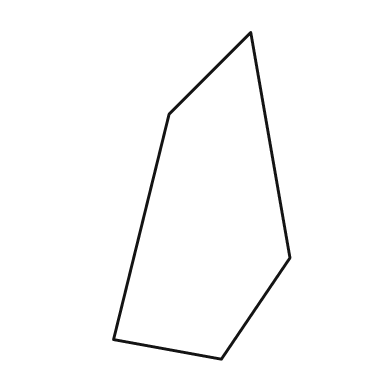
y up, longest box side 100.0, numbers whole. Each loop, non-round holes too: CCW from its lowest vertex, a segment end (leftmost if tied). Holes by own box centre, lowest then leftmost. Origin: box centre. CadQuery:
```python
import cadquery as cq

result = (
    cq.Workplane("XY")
    .moveTo(6.0, -50.0)
    .lineTo(27.0, -19.0)
    .lineTo(15.0, 50.0)
    .lineTo(-10.0, 25.0)
    .lineTo(-27.0, -44.0)
    .close()
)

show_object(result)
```